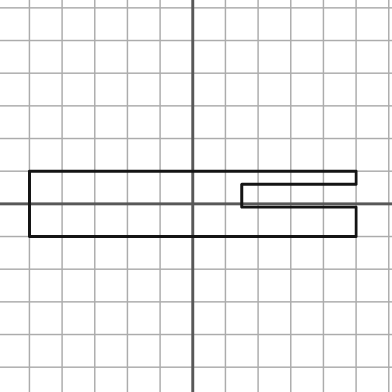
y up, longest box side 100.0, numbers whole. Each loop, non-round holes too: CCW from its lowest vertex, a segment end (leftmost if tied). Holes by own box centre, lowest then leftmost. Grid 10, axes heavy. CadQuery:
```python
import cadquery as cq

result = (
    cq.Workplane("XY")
    .moveTo(-50.0, -10.0)
    .lineTo(50.0, -10.0)
    .lineTo(50.0, -1.0)
    .lineTo(15.0, -1.0)
    .lineTo(15.0, 6.0)
    .lineTo(50.0, 6.0)
    .lineTo(50.0, 10.0)
    .lineTo(-50.0, 10.0)
    .close()
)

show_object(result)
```